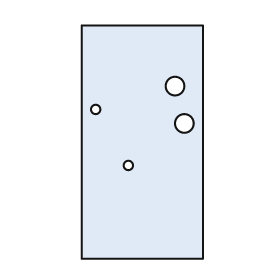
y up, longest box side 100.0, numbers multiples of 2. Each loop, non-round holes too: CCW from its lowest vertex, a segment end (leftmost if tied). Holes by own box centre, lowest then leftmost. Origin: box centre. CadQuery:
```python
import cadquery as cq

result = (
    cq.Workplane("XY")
    .moveTo(-26.0, -50.0)
    .lineTo(26.0, -50.0)
    .lineTo(26.0, 50.0)
    .lineTo(-26.0, 50.0)
    .close()
    .moveTo(-6.0, -10.0)
    .circle(2.0)
    .moveTo(18.0, 8.0)
    .circle(4.0)
    .moveTo(-20.0, 14.0)
    .circle(2.0)
    .moveTo(14.0, 24.0)
    .circle(4.0)
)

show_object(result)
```